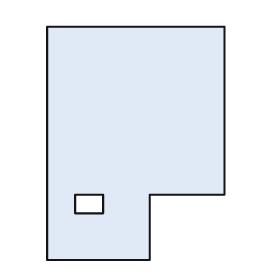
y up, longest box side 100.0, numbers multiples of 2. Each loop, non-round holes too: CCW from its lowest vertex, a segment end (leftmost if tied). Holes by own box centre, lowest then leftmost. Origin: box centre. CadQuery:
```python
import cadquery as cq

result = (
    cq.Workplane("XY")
    .moveTo(-38.0, -50.0)
    .lineTo(6.0, -50.0)
    .lineTo(6.0, -22.0)
    .lineTo(38.0, -22.0)
    .lineTo(38.0, 50.0)
    .lineTo(-38.0, 50.0)
    .close()
    .moveTo(-26.0, -30.0)
    .lineTo(-14.0, -30.0)
    .lineTo(-14.0, -22.0)
    .lineTo(-26.0, -22.0)
    .close()
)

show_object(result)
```